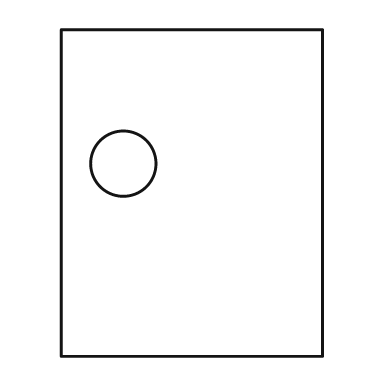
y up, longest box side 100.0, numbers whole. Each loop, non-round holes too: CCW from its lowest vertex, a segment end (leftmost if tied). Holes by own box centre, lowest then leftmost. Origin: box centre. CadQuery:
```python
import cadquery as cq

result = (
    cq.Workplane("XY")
    .moveTo(-40.0, -50.0)
    .lineTo(40.0, -50.0)
    .lineTo(40.0, 50.0)
    .lineTo(-40.0, 50.0)
    .close()
    .moveTo(-21.0, 9.0)
    .circle(10.0)
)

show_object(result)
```